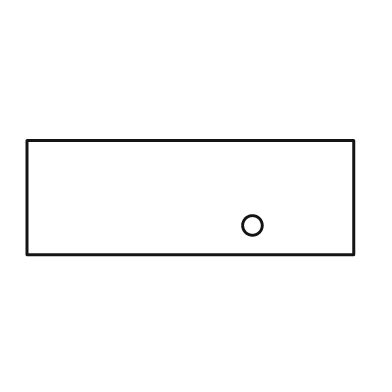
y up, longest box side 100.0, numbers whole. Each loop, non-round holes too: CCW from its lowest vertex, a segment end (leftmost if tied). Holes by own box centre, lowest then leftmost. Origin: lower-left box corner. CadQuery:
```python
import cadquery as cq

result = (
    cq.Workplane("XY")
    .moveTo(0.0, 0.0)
    .lineTo(100.0, 0.0)
    .lineTo(100.0, 35.0)
    .lineTo(0.0, 35.0)
    .close()
    .moveTo(69.0, 9.0)
    .circle(3.0)
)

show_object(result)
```